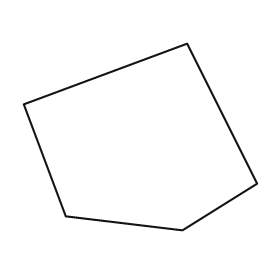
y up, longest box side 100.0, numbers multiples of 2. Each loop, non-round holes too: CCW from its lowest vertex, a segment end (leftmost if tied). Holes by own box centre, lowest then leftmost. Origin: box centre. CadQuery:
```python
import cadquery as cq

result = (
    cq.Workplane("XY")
    .moveTo(18.0, -40.0)
    .lineTo(50.0, -20.0)
    .lineTo(20.0, 40.0)
    .lineTo(-50.0, 14.0)
    .lineTo(-32.0, -34.0)
    .close()
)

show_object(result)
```